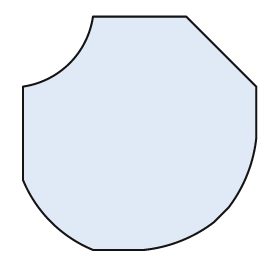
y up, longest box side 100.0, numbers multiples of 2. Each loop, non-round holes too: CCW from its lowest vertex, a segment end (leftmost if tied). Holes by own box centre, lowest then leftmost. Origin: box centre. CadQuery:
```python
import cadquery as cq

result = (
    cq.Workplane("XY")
    .moveTo(-20.0, -50.0)
    .lineTo(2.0, -50.0)
    .threePointArc((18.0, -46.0), (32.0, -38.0))
    .lineTo(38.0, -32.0)
    .threePointArc((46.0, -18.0), (50.0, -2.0))
    .lineTo(50.0, 20.0)
    .lineTo(20.0, 50.0)
    .lineTo(-20.0, 50.0)
    .threePointArc((-30.0, 30.0), (-50.0, 20.0))
    .lineTo(-50.0, -20.0)
    .threePointArc((-38.0, -38.0), (-20.0, -50.0))
    .close()
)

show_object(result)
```